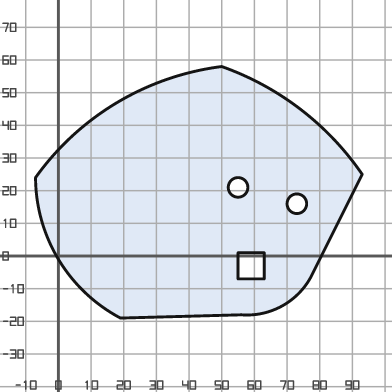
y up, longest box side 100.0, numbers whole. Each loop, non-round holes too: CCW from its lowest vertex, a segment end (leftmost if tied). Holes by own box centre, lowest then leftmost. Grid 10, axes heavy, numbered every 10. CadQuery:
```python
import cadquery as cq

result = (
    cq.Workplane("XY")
    .moveTo(19.0, -19.0)
    .lineTo(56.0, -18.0)
    .threePointArc((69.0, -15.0), (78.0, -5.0))
    .lineTo(93.0, 25.0)
    .threePointArc((74.0, 45.0), (50.0, 58.0))
    .threePointArc((18.0, 47.0), (-7.0, 24.0))
    .threePointArc((0.0, -1.0), (19.0, -19.0))
    .close()
    .moveTo(55.0, -7.0)
    .lineTo(63.0, -7.0)
    .lineTo(63.0, 1.0)
    .lineTo(55.0, 1.0)
    .close()
    .moveTo(73.0, 16.0)
    .circle(3.0)
    .moveTo(55.0, 21.0)
    .circle(3.0)
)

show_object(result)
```